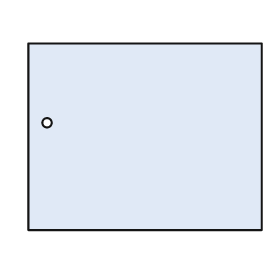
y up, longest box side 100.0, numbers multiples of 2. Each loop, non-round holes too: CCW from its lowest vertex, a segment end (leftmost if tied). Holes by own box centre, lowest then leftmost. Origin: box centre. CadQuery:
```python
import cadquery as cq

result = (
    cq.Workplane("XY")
    .moveTo(-50.0, -40.0)
    .lineTo(50.0, -40.0)
    .lineTo(50.0, 40.0)
    .lineTo(-50.0, 40.0)
    .close()
    .moveTo(-42.0, 6.0)
    .circle(2.0)
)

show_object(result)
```